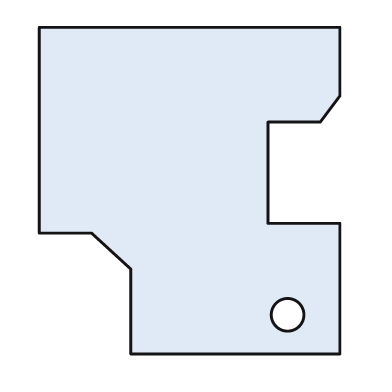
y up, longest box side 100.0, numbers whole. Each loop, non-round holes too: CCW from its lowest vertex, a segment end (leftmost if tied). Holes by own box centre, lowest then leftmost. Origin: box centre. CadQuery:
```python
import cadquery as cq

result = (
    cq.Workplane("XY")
    .moveTo(-18.0, -50.0)
    .lineTo(46.0, -50.0)
    .lineTo(46.0, -10.0)
    .lineTo(24.0, -10.0)
    .lineTo(24.0, 21.0)
    .lineTo(40.0, 21.0)
    .lineTo(46.0, 29.0)
    .lineTo(46.0, 50.0)
    .lineTo(-46.0, 50.0)
    .lineTo(-46.0, -13.0)
    .lineTo(-30.0, -13.0)
    .lineTo(-18.0, -24.0)
    .close()
    .moveTo(30.0, -38.0)
    .circle(5.0)
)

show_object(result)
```